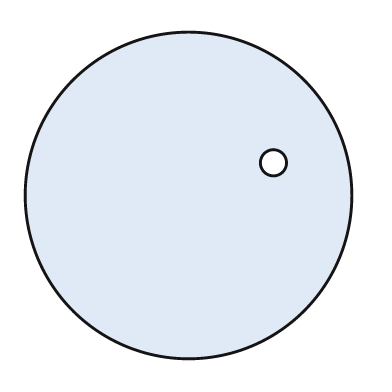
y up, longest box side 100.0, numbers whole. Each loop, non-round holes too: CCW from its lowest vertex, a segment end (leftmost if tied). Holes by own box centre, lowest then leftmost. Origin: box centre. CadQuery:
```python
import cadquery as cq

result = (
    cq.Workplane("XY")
    .moveTo(0.0, 0.0)
    .circle(50.0)
    .moveTo(26.0, 10.0)
    .circle(4.0)
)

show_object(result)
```